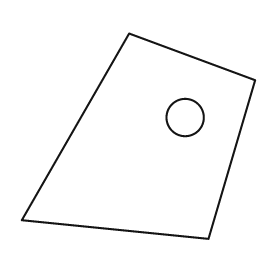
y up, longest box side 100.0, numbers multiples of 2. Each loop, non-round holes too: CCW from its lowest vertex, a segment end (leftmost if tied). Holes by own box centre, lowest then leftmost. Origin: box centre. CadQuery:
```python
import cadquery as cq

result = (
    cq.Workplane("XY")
    .moveTo(30.0, -44.0)
    .lineTo(50.0, 24.0)
    .lineTo(-4.0, 44.0)
    .lineTo(-50.0, -36.0)
    .close()
    .moveTo(20.0, 8.0)
    .circle(8.0)
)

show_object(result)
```